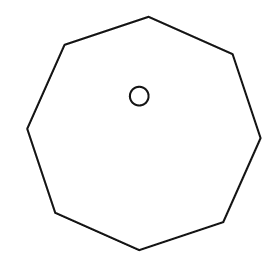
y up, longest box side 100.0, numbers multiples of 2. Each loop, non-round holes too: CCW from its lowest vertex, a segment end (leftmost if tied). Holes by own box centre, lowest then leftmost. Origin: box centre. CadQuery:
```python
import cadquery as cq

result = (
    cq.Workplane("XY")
    .moveTo(-2.0, -50.0)
    .lineTo(34.0, -38.0)
    .lineTo(50.0, -2.0)
    .lineTo(38.0, 34.0)
    .lineTo(2.0, 50.0)
    .lineTo(-34.0, 38.0)
    .lineTo(-50.0, 2.0)
    .lineTo(-38.0, -34.0)
    .close()
    .moveTo(-2.0, 16.0)
    .circle(4.0)
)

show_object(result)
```